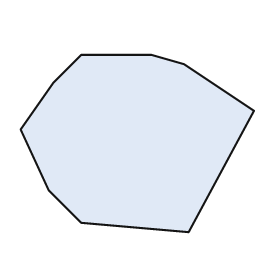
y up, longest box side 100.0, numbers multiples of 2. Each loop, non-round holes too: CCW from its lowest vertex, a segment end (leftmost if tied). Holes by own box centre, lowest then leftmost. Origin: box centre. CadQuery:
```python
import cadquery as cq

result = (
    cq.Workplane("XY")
    .moveTo(22.0, -38.0)
    .lineTo(50.0, 14.0)
    .lineTo(20.0, 34.0)
    .lineTo(6.0, 38.0)
    .lineTo(-24.0, 38.0)
    .lineTo(-36.0, 26.0)
    .lineTo(-50.0, 6.0)
    .lineTo(-38.0, -20.0)
    .lineTo(-24.0, -34.0)
    .close()
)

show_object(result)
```